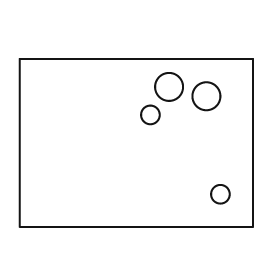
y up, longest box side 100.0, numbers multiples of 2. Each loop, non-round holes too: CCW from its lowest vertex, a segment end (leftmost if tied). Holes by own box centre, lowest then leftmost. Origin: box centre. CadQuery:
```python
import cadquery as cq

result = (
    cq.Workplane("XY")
    .moveTo(-50.0, -36.0)
    .lineTo(50.0, -36.0)
    .lineTo(50.0, 36.0)
    .lineTo(-50.0, 36.0)
    .close()
    .moveTo(36.0, -22.0)
    .circle(4.0)
    .moveTo(6.0, 12.0)
    .circle(4.0)
    .moveTo(30.0, 20.0)
    .circle(6.0)
    .moveTo(14.0, 24.0)
    .circle(6.0)
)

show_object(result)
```